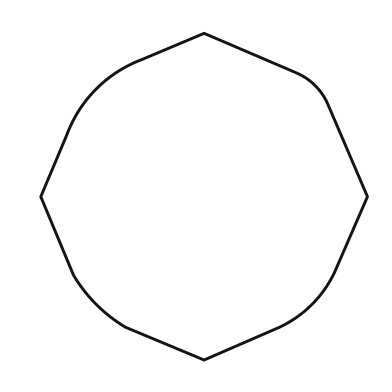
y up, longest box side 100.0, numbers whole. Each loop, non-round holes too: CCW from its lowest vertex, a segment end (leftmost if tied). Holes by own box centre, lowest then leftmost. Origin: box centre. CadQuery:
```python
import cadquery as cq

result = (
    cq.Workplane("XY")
    .moveTo(0.0, -50.0)
    .lineTo(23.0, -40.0)
    .threePointArc((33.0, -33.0), (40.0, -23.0))
    .lineTo(50.0, 0.0)
    .lineTo(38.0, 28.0)
    .threePointArc((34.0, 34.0), (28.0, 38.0))
    .lineTo(0.0, 50.0)
    .lineTo(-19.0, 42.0)
    .threePointArc((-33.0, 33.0), (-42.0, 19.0))
    .lineTo(-50.0, 0.0)
    .lineTo(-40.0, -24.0)
    .threePointArc((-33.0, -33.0), (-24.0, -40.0))
    .close()
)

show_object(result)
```